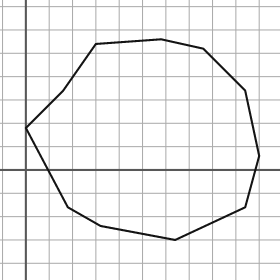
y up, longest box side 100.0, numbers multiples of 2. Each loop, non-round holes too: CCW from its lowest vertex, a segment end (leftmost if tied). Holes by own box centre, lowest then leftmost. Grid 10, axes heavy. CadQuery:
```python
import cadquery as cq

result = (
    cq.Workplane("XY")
    .moveTo(64.0, -30.0)
    .lineTo(94.0, -16.0)
    .lineTo(100.0, 6.0)
    .lineTo(94.0, 34.0)
    .lineTo(76.0, 52.0)
    .lineTo(58.0, 56.0)
    .lineTo(30.0, 54.0)
    .lineTo(16.0, 34.0)
    .lineTo(0.0, 18.0)
    .lineTo(18.0, -16.0)
    .lineTo(32.0, -24.0)
    .close()
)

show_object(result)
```